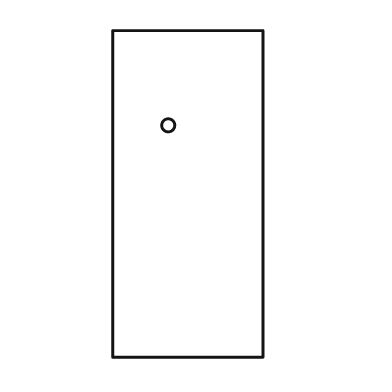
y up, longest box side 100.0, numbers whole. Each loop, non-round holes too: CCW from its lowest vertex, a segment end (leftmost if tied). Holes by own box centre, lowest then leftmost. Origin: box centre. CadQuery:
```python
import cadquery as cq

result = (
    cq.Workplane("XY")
    .moveTo(-23.0, -50.0)
    .lineTo(23.0, -50.0)
    .lineTo(23.0, 50.0)
    .lineTo(-23.0, 50.0)
    .close()
    .moveTo(-6.0, 21.0)
    .circle(2.0)
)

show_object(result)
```